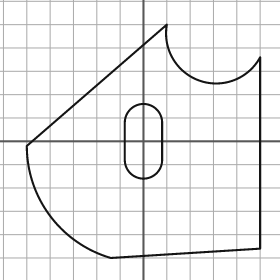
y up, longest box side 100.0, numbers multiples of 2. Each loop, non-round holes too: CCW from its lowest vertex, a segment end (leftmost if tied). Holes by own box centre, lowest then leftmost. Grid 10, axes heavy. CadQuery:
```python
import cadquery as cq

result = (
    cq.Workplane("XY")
    .moveTo(-14.0, -50.0)
    .lineTo(50.0, -46.0)
    .lineTo(50.0, 36.0)
    .threePointArc((24.0, 26.0), (10.0, 50.0))
    .lineTo(-50.0, -2.0)
    .threePointArc((-40.0, -32.0), (-14.0, -50.0))
    .close()
    .moveTo(-8.0, -8.0)
    .threePointArc((0.0, -16.0), (8.0, -8.0))
    .lineTo(8.0, 8.0)
    .threePointArc((0.0, 16.0), (-8.0, 8.0))
    .close()
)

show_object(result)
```